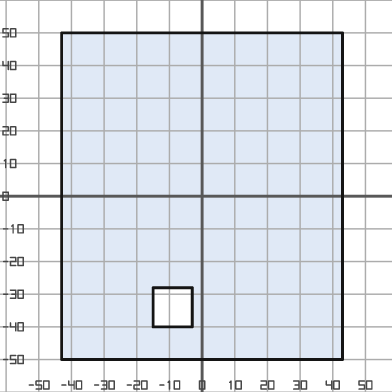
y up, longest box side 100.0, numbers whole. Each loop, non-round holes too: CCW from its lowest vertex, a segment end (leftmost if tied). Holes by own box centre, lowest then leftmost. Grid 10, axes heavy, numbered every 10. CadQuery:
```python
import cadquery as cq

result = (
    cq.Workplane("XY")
    .moveTo(-43.0, -50.0)
    .lineTo(43.0, -50.0)
    .lineTo(43.0, 50.0)
    .lineTo(-43.0, 50.0)
    .close()
    .moveTo(-15.0, -40.0)
    .lineTo(-3.0, -40.0)
    .lineTo(-3.0, -28.0)
    .lineTo(-15.0, -28.0)
    .close()
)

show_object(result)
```